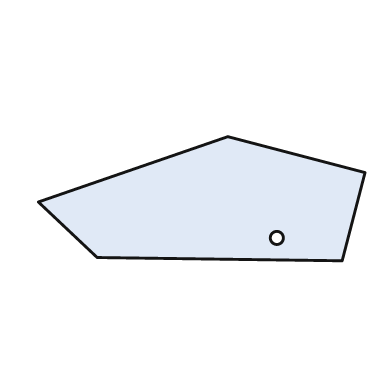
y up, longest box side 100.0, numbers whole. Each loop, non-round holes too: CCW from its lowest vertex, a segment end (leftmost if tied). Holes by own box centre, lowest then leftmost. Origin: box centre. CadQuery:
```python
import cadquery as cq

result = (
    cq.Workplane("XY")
    .moveTo(43.0, -19.0)
    .lineTo(50.0, 8.0)
    .lineTo(8.0, 19.0)
    .lineTo(-50.0, -1.0)
    .lineTo(-32.0, -18.0)
    .close()
    .moveTo(23.0, -12.0)
    .circle(2.0)
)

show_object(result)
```